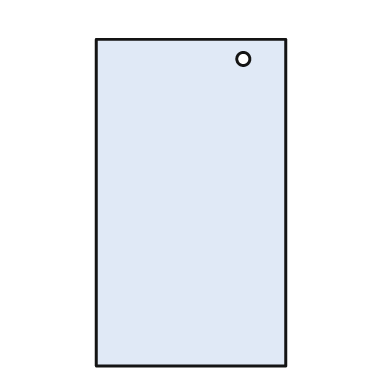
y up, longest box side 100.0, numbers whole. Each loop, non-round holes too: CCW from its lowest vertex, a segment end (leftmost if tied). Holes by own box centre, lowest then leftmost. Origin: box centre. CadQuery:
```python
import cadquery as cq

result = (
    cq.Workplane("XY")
    .moveTo(-29.0, -50.0)
    .lineTo(29.0, -50.0)
    .lineTo(29.0, 50.0)
    .lineTo(-29.0, 50.0)
    .close()
    .moveTo(16.0, 44.0)
    .circle(2.0)
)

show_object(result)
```